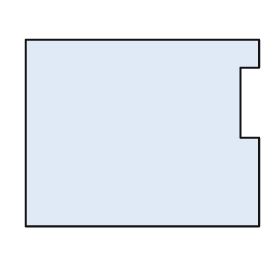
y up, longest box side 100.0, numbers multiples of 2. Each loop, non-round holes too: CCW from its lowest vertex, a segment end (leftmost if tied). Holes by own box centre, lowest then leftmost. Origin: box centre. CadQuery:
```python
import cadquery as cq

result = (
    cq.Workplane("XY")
    .moveTo(-50.0, -40.0)
    .lineTo(50.0, -40.0)
    .lineTo(50.0, -2.0)
    .lineTo(42.0, -2.0)
    .lineTo(42.0, 28.0)
    .lineTo(50.0, 28.0)
    .lineTo(50.0, 40.0)
    .lineTo(-50.0, 40.0)
    .close()
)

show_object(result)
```